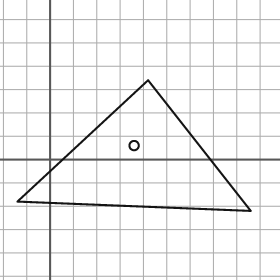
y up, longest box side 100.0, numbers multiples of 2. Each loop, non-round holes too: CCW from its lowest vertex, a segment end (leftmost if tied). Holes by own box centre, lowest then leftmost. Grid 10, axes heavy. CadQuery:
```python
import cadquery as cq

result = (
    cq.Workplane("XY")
    .moveTo(86.0, -22.0)
    .lineTo(42.0, 34.0)
    .lineTo(-14.0, -18.0)
    .close()
    .moveTo(36.0, 6.0)
    .circle(2.0)
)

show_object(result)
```